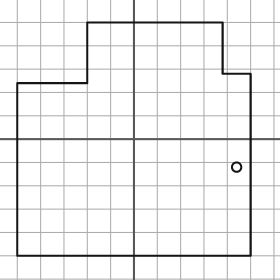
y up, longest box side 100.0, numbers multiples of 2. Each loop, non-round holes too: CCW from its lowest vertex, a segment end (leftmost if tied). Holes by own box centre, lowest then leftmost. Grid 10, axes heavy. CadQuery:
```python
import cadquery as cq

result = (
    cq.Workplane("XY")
    .moveTo(-50.0, -50.0)
    .lineTo(50.0, -50.0)
    .lineTo(50.0, 28.0)
    .lineTo(38.0, 28.0)
    .lineTo(38.0, 50.0)
    .lineTo(-20.0, 50.0)
    .lineTo(-20.0, 24.0)
    .lineTo(-50.0, 24.0)
    .close()
    .moveTo(44.0, -12.0)
    .circle(2.0)
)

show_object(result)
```